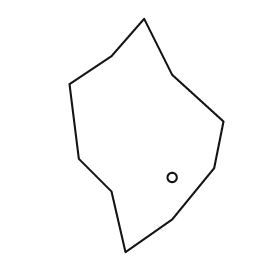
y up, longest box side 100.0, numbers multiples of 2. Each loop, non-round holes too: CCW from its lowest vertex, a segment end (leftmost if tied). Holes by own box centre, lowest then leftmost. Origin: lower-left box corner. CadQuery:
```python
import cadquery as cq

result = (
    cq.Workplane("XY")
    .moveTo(24.0, 0.0)
    .lineTo(44.0, 14.0)
    .lineTo(62.0, 36.0)
    .lineTo(66.0, 56.0)
    .lineTo(44.0, 76.0)
    .lineTo(32.0, 100.0)
    .lineTo(18.0, 84.0)
    .lineTo(0.0, 72.0)
    .lineTo(4.0, 40.0)
    .lineTo(18.0, 26.0)
    .close()
    .moveTo(44.0, 32.0)
    .circle(2.0)
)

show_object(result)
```